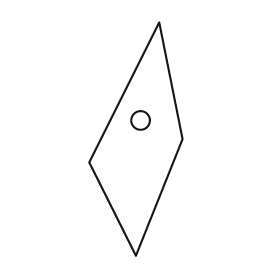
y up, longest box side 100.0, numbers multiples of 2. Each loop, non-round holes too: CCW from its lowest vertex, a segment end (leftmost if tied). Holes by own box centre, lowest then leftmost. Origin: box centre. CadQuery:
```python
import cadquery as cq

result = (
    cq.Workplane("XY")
    .moveTo(0.0, -50.0)
    .lineTo(20.0, 0.0)
    .lineTo(10.0, 50.0)
    .lineTo(-20.0, -10.0)
    .close()
    .moveTo(2.0, 8.0)
    .circle(4.0)
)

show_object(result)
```